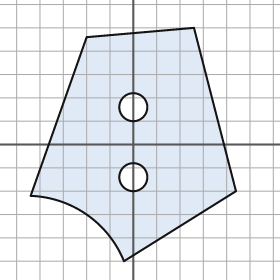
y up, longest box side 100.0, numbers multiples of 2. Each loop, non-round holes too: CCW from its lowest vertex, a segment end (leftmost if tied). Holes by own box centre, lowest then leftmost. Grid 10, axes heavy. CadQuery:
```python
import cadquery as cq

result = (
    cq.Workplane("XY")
    .moveTo(-4.0, -50.0)
    .lineTo(44.0, -20.0)
    .lineTo(26.0, 50.0)
    .lineTo(-20.0, 46.0)
    .lineTo(-44.0, -22.0)
    .threePointArc((-20.0, -30.0), (-4.0, -50.0))
    .close()
    .moveTo(0.0, -14.0)
    .circle(6.0)
    .moveTo(0.0, 16.0)
    .circle(6.0)
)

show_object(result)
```